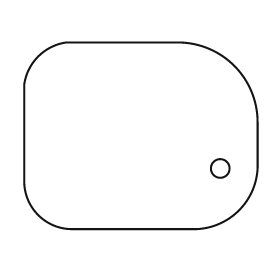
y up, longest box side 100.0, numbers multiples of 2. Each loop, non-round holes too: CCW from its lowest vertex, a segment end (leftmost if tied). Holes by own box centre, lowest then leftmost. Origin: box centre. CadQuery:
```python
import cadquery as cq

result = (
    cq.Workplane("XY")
    .moveTo(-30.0, -40.0)
    .lineTo(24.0, -40.0)
    .threePointArc((42.0, -32.0), (50.0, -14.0))
    .lineTo(50.0, 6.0)
    .threePointArc((40.0, 30.0), (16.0, 40.0))
    .lineTo(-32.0, 40.0)
    .threePointArc((-44.0, 34.0), (-50.0, 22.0))
    .lineTo(-50.0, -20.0)
    .threePointArc((-44.0, -34.0), (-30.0, -40.0))
    .close()
    .moveTo(34.0, -14.0)
    .circle(4.0)
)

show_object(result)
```